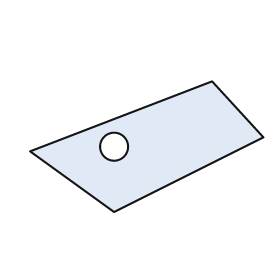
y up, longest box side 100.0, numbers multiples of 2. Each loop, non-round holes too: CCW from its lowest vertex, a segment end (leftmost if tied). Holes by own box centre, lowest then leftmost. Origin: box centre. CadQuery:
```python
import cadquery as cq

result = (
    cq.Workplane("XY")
    .moveTo(-14.0, -28.0)
    .lineTo(50.0, 4.0)
    .lineTo(28.0, 28.0)
    .lineTo(-50.0, -2.0)
    .close()
    .moveTo(-14.0, 0.0)
    .circle(6.0)
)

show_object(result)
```